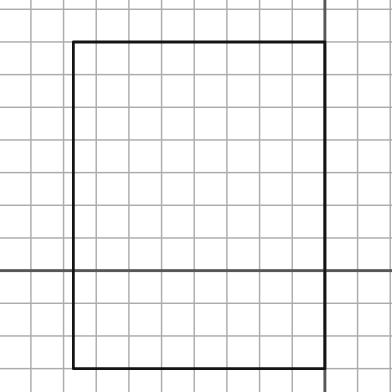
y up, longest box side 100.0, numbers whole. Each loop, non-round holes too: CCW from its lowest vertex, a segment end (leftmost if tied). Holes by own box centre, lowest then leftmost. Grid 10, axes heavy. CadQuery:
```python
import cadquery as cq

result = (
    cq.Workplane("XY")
    .moveTo(-77.0, -30.0)
    .lineTo(0.0, -30.0)
    .lineTo(0.0, 70.0)
    .lineTo(-77.0, 70.0)
    .close()
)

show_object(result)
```